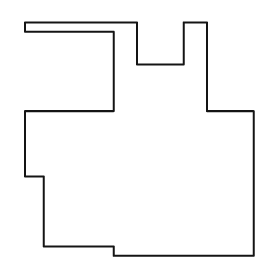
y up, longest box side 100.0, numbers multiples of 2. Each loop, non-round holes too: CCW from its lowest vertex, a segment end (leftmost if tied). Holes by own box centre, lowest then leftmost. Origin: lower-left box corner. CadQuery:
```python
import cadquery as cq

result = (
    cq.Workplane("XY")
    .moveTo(38.0, 0.0)
    .lineTo(98.0, 0.0)
    .lineTo(98.0, 62.0)
    .lineTo(78.0, 62.0)
    .lineTo(78.0, 100.0)
    .lineTo(68.0, 100.0)
    .lineTo(68.0, 82.0)
    .lineTo(48.0, 82.0)
    .lineTo(48.0, 100.0)
    .lineTo(0.0, 100.0)
    .lineTo(0.0, 96.0)
    .lineTo(38.0, 96.0)
    .lineTo(38.0, 62.0)
    .lineTo(0.0, 62.0)
    .lineTo(0.0, 34.0)
    .lineTo(8.0, 34.0)
    .lineTo(8.0, 4.0)
    .lineTo(38.0, 4.0)
    .close()
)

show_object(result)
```